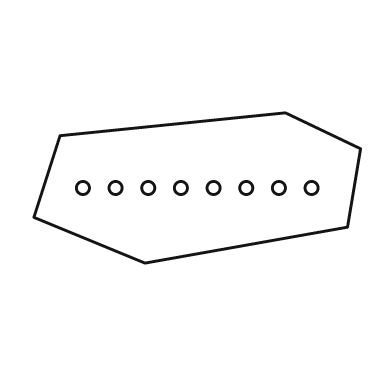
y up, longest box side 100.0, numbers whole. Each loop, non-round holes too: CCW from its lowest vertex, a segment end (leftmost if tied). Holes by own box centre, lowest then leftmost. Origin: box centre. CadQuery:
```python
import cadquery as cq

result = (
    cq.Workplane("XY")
    .moveTo(-16.0, -23.0)
    .lineTo(46.0, -12.0)
    .lineTo(50.0, 12.0)
    .lineTo(27.0, 23.0)
    .lineTo(-42.0, 16.0)
    .lineTo(-50.0, -9.0)
    .close()
    .moveTo(-35.0, 0.0)
    .circle(2.0)
    .moveTo(-25.0, 0.0)
    .circle(2.0)
    .moveTo(-15.0, 0.0)
    .circle(2.0)
    .moveTo(-5.0, 0.0)
    .circle(2.0)
    .moveTo(5.0, 0.0)
    .circle(2.0)
    .moveTo(15.0, 0.0)
    .circle(2.0)
    .moveTo(25.0, 0.0)
    .circle(2.0)
    .moveTo(35.0, 0.0)
    .circle(2.0)
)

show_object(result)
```